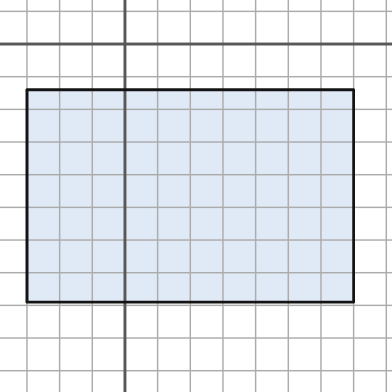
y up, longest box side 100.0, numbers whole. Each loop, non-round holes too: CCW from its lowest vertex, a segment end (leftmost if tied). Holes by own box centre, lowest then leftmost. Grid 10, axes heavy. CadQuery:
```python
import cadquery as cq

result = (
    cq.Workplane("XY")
    .moveTo(-30.0, -79.0)
    .lineTo(70.0, -79.0)
    .lineTo(70.0, -14.0)
    .lineTo(-30.0, -14.0)
    .close()
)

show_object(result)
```